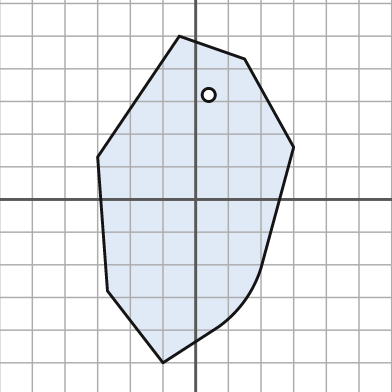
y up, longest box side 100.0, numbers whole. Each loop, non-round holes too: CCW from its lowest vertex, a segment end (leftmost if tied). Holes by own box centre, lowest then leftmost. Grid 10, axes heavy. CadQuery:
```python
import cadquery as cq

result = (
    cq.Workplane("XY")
    .moveTo(-10.0, -50.0)
    .lineTo(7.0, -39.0)
    .threePointArc((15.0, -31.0), (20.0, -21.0))
    .lineTo(30.0, 16.0)
    .lineTo(15.0, 43.0)
    .lineTo(-5.0, 50.0)
    .lineTo(-30.0, 13.0)
    .lineTo(-27.0, -28.0)
    .close()
    .moveTo(4.0, 32.0)
    .circle(2.0)
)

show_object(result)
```